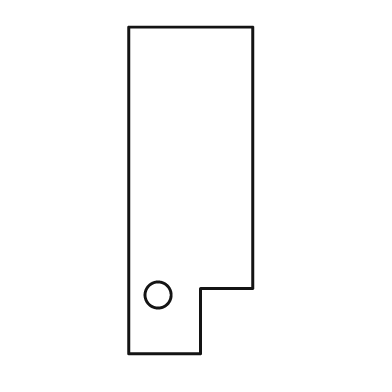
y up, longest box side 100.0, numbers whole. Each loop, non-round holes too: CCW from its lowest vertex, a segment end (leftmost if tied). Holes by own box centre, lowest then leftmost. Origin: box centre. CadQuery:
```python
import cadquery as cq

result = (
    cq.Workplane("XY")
    .moveTo(-19.0, -50.0)
    .lineTo(3.0, -50.0)
    .lineTo(3.0, -30.0)
    .lineTo(19.0, -30.0)
    .lineTo(19.0, 50.0)
    .lineTo(-19.0, 50.0)
    .close()
    .moveTo(-10.0, -32.0)
    .circle(4.0)
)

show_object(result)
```